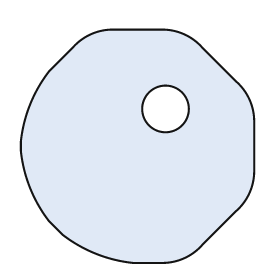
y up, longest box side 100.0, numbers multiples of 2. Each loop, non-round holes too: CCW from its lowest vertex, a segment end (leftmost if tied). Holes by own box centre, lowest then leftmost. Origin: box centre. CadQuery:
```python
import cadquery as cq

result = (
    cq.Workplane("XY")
    .moveTo(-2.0, -50.0)
    .lineTo(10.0, -50.0)
    .threePointArc((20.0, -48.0), (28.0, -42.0))
    .lineTo(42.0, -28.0)
    .threePointArc((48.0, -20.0), (50.0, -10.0))
    .lineTo(50.0, 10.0)
    .threePointArc((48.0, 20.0), (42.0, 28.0))
    .lineTo(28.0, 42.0)
    .threePointArc((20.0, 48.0), (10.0, 50.0))
    .lineTo(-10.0, 50.0)
    .threePointArc((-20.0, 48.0), (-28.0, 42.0))
    .lineTo(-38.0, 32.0)
    .threePointArc((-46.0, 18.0), (-50.0, 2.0))
    .lineTo(-50.0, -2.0)
    .threePointArc((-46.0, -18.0), (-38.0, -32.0))
    .lineTo(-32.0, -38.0)
    .threePointArc((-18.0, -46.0), (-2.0, -50.0))
    .close()
    .moveTo(12.0, 16.0)
    .circle(10.0)
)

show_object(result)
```